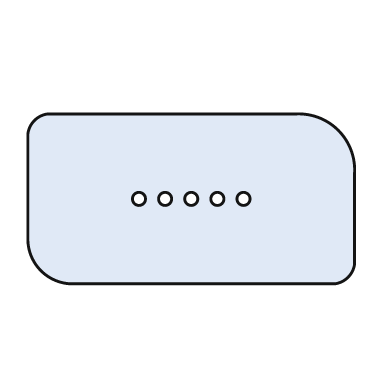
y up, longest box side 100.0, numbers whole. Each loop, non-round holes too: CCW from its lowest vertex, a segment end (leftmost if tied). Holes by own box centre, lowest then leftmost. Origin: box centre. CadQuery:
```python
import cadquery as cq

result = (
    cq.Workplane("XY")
    .moveTo(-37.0, -26.0)
    .lineTo(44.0, -26.0)
    .threePointArc((48.0, -24.0), (50.0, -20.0))
    .lineTo(50.0, 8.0)
    .threePointArc((45.0, 21.0), (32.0, 26.0))
    .lineTo(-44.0, 26.0)
    .threePointArc((-48.0, 24.0), (-50.0, 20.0))
    .lineTo(-50.0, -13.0)
    .threePointArc((-46.0, -22.0), (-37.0, -26.0))
    .close()
    .moveTo(-16.0, 0.0)
    .circle(2.0)
    .moveTo(-8.0, 0.0)
    .circle(2.0)
    .moveTo(0.0, 0.0)
    .circle(2.0)
    .moveTo(8.0, 0.0)
    .circle(2.0)
    .moveTo(16.0, 0.0)
    .circle(2.0)
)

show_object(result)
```